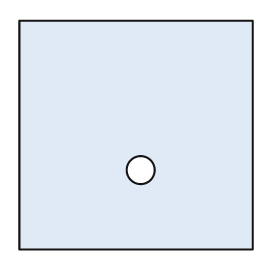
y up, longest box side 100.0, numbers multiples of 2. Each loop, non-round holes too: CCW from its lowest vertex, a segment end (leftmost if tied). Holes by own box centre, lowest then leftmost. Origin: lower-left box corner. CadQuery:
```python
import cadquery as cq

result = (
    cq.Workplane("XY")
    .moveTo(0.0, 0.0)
    .lineTo(100.0, 0.0)
    .lineTo(100.0, 98.0)
    .lineTo(0.0, 98.0)
    .close()
    .moveTo(52.0, 34.0)
    .circle(6.0)
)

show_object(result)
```